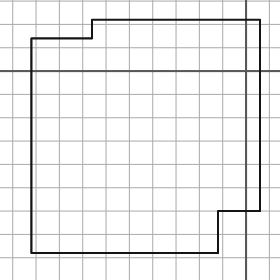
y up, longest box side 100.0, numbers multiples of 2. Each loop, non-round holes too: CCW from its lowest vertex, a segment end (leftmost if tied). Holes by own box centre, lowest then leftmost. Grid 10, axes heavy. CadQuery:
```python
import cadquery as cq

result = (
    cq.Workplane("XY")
    .moveTo(-92.0, -78.0)
    .lineTo(-12.0, -78.0)
    .lineTo(-12.0, -60.0)
    .lineTo(6.0, -60.0)
    .lineTo(6.0, 22.0)
    .lineTo(-66.0, 22.0)
    .lineTo(-66.0, 14.0)
    .lineTo(-92.0, 14.0)
    .close()
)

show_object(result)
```